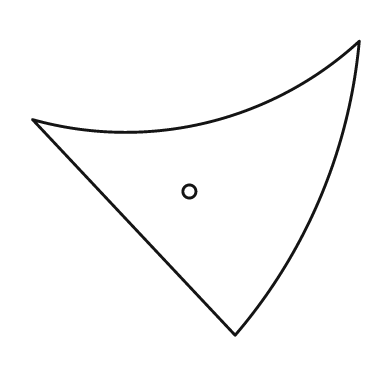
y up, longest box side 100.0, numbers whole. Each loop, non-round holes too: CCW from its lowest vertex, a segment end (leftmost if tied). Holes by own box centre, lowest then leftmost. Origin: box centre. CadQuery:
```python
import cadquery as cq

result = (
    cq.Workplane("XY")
    .moveTo(12.0, -45.0)
    .threePointArc((38.0, -3.0), (50.0, 45.0))
    .threePointArc((3.0, 20.0), (-50.0, 21.0))
    .close()
    .moveTo(-2.0, -1.0)
    .circle(2.0)
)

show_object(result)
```